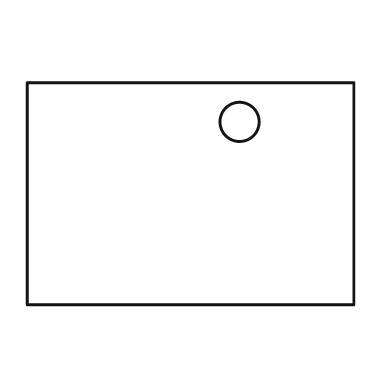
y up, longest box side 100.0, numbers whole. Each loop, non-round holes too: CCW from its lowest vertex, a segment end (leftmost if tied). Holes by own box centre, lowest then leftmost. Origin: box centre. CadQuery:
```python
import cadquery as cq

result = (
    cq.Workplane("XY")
    .moveTo(-50.0, -34.0)
    .lineTo(50.0, -34.0)
    .lineTo(50.0, 34.0)
    .lineTo(-50.0, 34.0)
    .close()
    .moveTo(15.0, 22.0)
    .circle(6.0)
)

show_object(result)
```